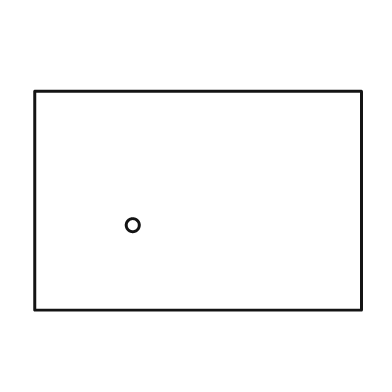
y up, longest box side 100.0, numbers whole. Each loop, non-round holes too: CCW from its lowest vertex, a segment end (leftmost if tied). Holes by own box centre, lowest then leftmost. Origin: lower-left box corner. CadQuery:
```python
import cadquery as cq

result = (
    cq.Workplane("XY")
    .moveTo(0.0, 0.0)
    .lineTo(100.0, 0.0)
    .lineTo(100.0, 67.0)
    .lineTo(0.0, 67.0)
    .close()
    .moveTo(30.0, 26.0)
    .circle(2.0)
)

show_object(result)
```